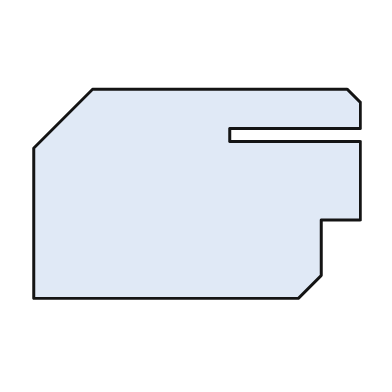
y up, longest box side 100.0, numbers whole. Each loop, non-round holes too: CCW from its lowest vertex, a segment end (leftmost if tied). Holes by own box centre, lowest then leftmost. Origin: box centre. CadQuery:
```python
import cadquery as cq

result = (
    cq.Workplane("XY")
    .moveTo(-50.0, -32.0)
    .lineTo(31.0, -32.0)
    .lineTo(38.0, -25.0)
    .lineTo(38.0, -8.0)
    .lineTo(50.0, -8.0)
    .lineTo(50.0, 16.0)
    .lineTo(10.0, 16.0)
    .lineTo(10.0, 20.0)
    .lineTo(50.0, 20.0)
    .lineTo(50.0, 28.0)
    .lineTo(46.0, 32.0)
    .lineTo(-32.0, 32.0)
    .lineTo(-50.0, 14.0)
    .close()
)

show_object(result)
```